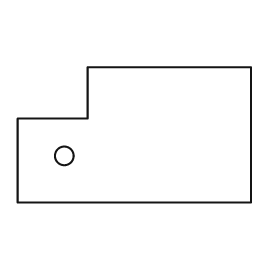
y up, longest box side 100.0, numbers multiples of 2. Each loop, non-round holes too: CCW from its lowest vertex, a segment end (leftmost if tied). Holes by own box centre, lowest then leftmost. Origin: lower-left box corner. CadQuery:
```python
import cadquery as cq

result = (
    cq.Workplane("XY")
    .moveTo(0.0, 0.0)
    .lineTo(100.0, 0.0)
    .lineTo(100.0, 58.0)
    .lineTo(30.0, 58.0)
    .lineTo(30.0, 36.0)
    .lineTo(0.0, 36.0)
    .close()
    .moveTo(20.0, 20.0)
    .circle(4.0)
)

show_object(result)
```